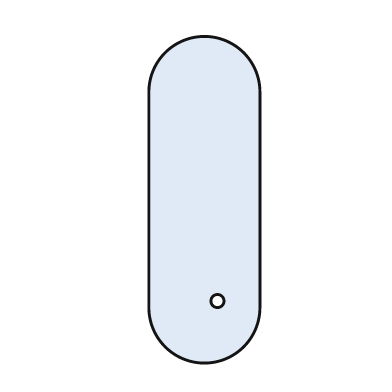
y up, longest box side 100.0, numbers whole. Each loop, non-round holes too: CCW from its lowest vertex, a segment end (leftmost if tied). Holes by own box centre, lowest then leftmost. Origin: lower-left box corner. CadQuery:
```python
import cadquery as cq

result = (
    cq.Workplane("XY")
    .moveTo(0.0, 17.0)
    .threePointArc((17.0, 0.0), (34.0, 17.0))
    .lineTo(34.0, 83.0)
    .threePointArc((17.0, 100.0), (0.0, 83.0))
    .close()
    .moveTo(21.0, 19.0)
    .circle(2.0)
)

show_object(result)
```